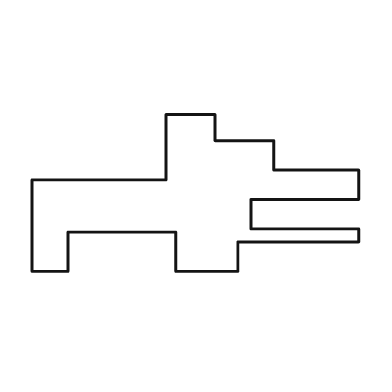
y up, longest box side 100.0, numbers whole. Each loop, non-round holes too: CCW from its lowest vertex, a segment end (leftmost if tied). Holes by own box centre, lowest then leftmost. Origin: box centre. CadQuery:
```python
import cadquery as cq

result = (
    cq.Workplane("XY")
    .moveTo(-50.0, -24.0)
    .lineTo(-39.0, -24.0)
    .lineTo(-39.0, -12.0)
    .lineTo(-6.0, -12.0)
    .lineTo(-6.0, -24.0)
    .lineTo(13.0, -24.0)
    .lineTo(13.0, -15.0)
    .lineTo(50.0, -15.0)
    .lineTo(50.0, -11.0)
    .lineTo(17.0, -11.0)
    .lineTo(17.0, -2.0)
    .lineTo(50.0, -2.0)
    .lineTo(50.0, 7.0)
    .lineTo(24.0, 7.0)
    .lineTo(24.0, 16.0)
    .lineTo(6.0, 16.0)
    .lineTo(6.0, 24.0)
    .lineTo(-9.0, 24.0)
    .lineTo(-9.0, 4.0)
    .lineTo(-50.0, 4.0)
    .close()
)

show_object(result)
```